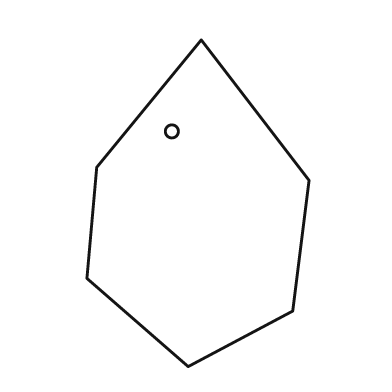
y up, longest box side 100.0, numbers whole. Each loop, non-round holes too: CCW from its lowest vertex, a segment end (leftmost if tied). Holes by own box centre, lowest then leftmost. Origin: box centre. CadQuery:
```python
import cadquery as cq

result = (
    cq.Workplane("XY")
    .moveTo(-3.0, -50.0)
    .lineTo(29.0, -33.0)
    .lineTo(34.0, 7.0)
    .lineTo(1.0, 50.0)
    .lineTo(-31.0, 11.0)
    .lineTo(-34.0, -23.0)
    .close()
    .moveTo(-8.0, 22.0)
    .circle(2.0)
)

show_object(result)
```